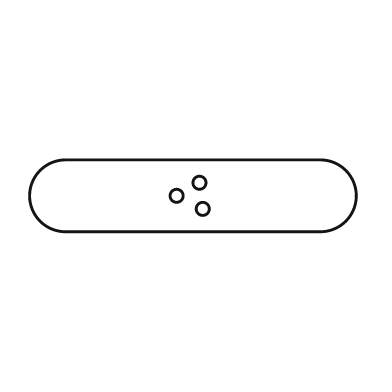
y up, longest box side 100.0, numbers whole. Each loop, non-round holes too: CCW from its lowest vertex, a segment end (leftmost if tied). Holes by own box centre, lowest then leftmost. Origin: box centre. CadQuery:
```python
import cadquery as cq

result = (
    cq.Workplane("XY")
    .moveTo(-39.0, -11.0)
    .lineTo(39.0, -11.0)
    .threePointArc((50.0, 0.0), (39.0, 11.0))
    .lineTo(-39.0, 11.0)
    .threePointArc((-50.0, 0.0), (-39.0, -11.0))
    .close()
    .moveTo(3.0, -4.0)
    .circle(2.0)
    .moveTo(-5.0, 0.0)
    .circle(2.0)
    .moveTo(2.0, 4.0)
    .circle(2.0)
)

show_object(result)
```